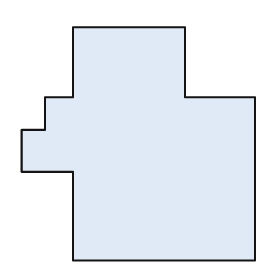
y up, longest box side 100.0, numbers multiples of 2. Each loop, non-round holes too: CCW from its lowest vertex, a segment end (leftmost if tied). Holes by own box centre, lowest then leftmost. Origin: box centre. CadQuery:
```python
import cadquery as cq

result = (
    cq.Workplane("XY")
    .moveTo(-28.0, -50.0)
    .lineTo(50.0, -50.0)
    .lineTo(50.0, 20.0)
    .lineTo(20.0, 20.0)
    .lineTo(20.0, 50.0)
    .lineTo(-28.0, 50.0)
    .lineTo(-28.0, 20.0)
    .lineTo(-40.0, 20.0)
    .lineTo(-40.0, 6.0)
    .lineTo(-50.0, 6.0)
    .lineTo(-50.0, -12.0)
    .lineTo(-28.0, -12.0)
    .close()
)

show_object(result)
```